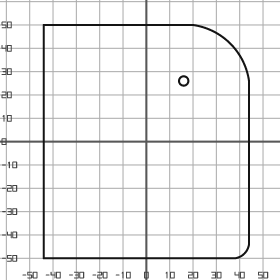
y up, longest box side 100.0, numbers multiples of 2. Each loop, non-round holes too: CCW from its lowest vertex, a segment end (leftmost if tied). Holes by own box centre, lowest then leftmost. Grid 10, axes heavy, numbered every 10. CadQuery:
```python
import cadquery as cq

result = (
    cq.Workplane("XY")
    .moveTo(-44.0, -50.0)
    .lineTo(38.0, -50.0)
    .threePointArc((42.0, -48.0), (44.0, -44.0))
    .lineTo(44.0, 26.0)
    .threePointArc((36.0, 42.0), (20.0, 50.0))
    .lineTo(-44.0, 50.0)
    .close()
    .moveTo(16.0, 26.0)
    .circle(2.0)
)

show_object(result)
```